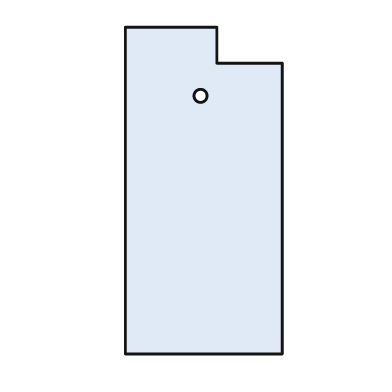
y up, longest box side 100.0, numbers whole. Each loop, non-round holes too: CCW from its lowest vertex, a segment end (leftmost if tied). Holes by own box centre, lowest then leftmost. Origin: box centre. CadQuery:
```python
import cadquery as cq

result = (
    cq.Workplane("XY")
    .moveTo(-24.0, -50.0)
    .lineTo(24.0, -50.0)
    .lineTo(24.0, 39.0)
    .lineTo(4.0, 39.0)
    .lineTo(4.0, 50.0)
    .lineTo(-24.0, 50.0)
    .close()
    .moveTo(-1.0, 29.0)
    .circle(2.0)
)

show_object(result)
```